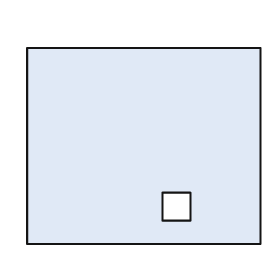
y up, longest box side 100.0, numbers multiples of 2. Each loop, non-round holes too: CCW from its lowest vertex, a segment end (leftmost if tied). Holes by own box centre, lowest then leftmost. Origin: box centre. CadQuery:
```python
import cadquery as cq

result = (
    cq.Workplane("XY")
    .moveTo(-50.0, -42.0)
    .lineTo(50.0, -42.0)
    .lineTo(50.0, 42.0)
    .lineTo(-50.0, 42.0)
    .close()
    .moveTo(8.0, -32.0)
    .lineTo(20.0, -32.0)
    .lineTo(20.0, -20.0)
    .lineTo(8.0, -20.0)
    .close()
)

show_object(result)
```